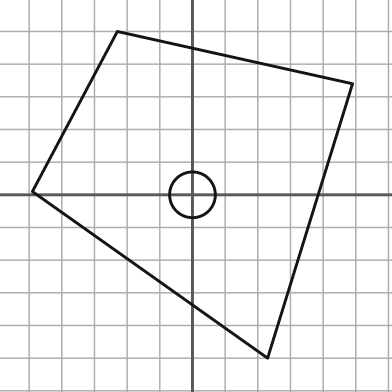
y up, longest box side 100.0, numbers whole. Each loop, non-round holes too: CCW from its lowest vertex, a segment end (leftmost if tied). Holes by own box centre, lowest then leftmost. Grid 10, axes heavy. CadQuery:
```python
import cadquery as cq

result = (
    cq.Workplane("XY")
    .moveTo(23.0, -50.0)
    .lineTo(49.0, 34.0)
    .lineTo(-23.0, 50.0)
    .lineTo(-49.0, 1.0)
    .close()
    .moveTo(0.0, 0.0)
    .circle(7.0)
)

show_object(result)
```